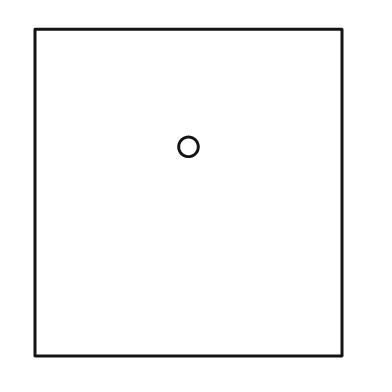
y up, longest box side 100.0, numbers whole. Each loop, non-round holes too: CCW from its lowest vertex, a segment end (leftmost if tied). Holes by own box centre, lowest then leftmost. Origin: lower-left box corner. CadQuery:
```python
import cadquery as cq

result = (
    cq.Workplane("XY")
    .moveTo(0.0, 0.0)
    .lineTo(94.0, 0.0)
    .lineTo(94.0, 100.0)
    .lineTo(0.0, 100.0)
    .close()
    .moveTo(47.0, 64.0)
    .circle(3.0)
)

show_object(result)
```